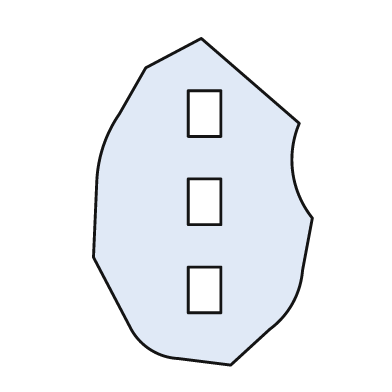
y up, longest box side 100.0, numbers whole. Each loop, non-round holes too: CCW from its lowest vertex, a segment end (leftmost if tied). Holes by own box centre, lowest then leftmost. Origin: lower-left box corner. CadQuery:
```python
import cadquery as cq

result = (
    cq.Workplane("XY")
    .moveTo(42.0, 0.0)
    .lineTo(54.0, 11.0)
    .threePointArc((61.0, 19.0), (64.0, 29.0))
    .lineTo(67.0, 45.0)
    .threePointArc((61.0, 59.0), (63.0, 74.0))
    .lineTo(33.0, 100.0)
    .lineTo(16.0, 91.0)
    .lineTo(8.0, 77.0)
    .threePointArc((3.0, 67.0), (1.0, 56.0))
    .lineTo(0.0, 33.0)
    .lineTo(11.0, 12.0)
    .threePointArc((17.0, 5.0), (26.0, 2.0))
    .close()
    .moveTo(29.0, 16.0)
    .lineTo(39.0, 16.0)
    .lineTo(39.0, 30.0)
    .lineTo(29.0, 30.0)
    .close()
    .moveTo(29.0, 43.0)
    .lineTo(39.0, 43.0)
    .lineTo(39.0, 57.0)
    .lineTo(29.0, 57.0)
    .close()
    .moveTo(29.0, 70.0)
    .lineTo(39.0, 70.0)
    .lineTo(39.0, 84.0)
    .lineTo(29.0, 84.0)
    .close()
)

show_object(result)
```